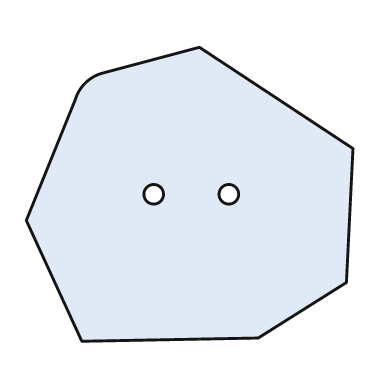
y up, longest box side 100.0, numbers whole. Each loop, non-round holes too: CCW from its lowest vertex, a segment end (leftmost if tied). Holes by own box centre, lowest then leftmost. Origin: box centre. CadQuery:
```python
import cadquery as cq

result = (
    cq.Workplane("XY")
    .moveTo(-33.0, -45.0)
    .lineTo(21.0, -44.0)
    .lineTo(48.0, -27.0)
    .lineTo(50.0, 14.0)
    .lineTo(3.0, 45.0)
    .lineTo(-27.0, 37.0)
    .threePointArc((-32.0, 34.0), (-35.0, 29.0))
    .lineTo(-50.0, -8.0)
    .close()
    .moveTo(-11.0, 0.0)
    .circle(3.0)
    .moveTo(12.0, 0.0)
    .circle(3.0)
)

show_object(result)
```